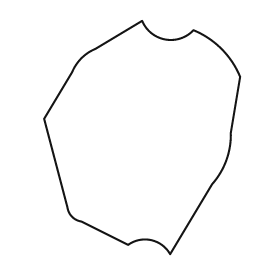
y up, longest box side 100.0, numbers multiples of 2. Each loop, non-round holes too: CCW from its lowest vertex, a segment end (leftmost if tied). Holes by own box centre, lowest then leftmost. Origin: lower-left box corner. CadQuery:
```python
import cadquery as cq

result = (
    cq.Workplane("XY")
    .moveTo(54.0, 0.0)
    .lineTo(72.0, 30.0)
    .threePointArc((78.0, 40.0), (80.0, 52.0))
    .lineTo(84.0, 76.0)
    .threePointArc((76.0, 88.0), (64.0, 96.0))
    .threePointArc((52.0, 92.0), (42.0, 100.0))
    .lineTo(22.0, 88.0)
    .threePointArc((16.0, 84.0), (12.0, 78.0))
    .lineTo(0.0, 58.0)
    .lineTo(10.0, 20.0)
    .threePointArc((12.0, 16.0), (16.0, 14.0))
    .lineTo(36.0, 4.0)
    .threePointArc((46.0, 6.0), (54.0, 0.0))
    .close()
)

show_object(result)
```